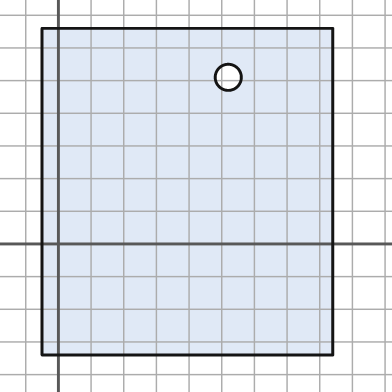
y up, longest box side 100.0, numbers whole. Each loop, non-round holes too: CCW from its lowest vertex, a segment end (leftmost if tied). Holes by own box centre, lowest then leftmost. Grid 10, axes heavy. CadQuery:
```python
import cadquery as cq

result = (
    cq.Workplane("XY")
    .moveTo(-5.0, -34.0)
    .lineTo(84.0, -34.0)
    .lineTo(84.0, 66.0)
    .lineTo(-5.0, 66.0)
    .close()
    .moveTo(52.0, 51.0)
    .circle(4.0)
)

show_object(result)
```